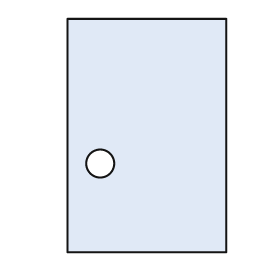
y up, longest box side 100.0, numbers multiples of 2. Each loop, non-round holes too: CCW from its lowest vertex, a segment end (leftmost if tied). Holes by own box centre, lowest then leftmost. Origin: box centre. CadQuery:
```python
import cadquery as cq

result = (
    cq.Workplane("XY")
    .moveTo(-34.0, -50.0)
    .lineTo(34.0, -50.0)
    .lineTo(34.0, 50.0)
    .lineTo(-34.0, 50.0)
    .close()
    .moveTo(-20.0, -12.0)
    .circle(6.0)
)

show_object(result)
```